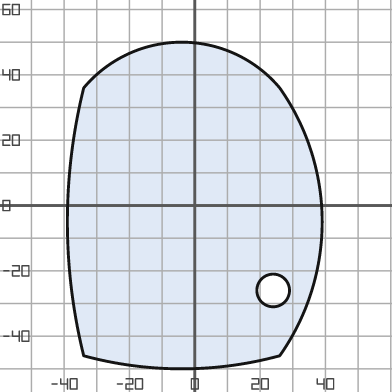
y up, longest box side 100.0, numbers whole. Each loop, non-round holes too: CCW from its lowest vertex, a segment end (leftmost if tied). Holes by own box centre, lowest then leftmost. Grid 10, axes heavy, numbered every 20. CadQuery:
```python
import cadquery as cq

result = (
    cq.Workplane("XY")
    .moveTo(-34.0, -46.0)
    .threePointArc((-4.0, -50.0), (26.0, -46.0))
    .threePointArc((39.0, -5.0), (26.0, 36.0))
    .threePointArc((-4.0, 50.0), (-34.0, 36.0))
    .threePointArc((-39.0, -5.0), (-34.0, -46.0))
    .close()
    .moveTo(24.0, -26.0)
    .circle(5.0)
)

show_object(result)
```